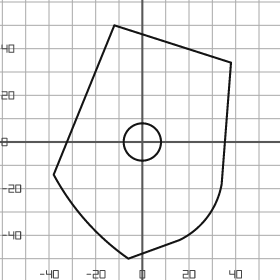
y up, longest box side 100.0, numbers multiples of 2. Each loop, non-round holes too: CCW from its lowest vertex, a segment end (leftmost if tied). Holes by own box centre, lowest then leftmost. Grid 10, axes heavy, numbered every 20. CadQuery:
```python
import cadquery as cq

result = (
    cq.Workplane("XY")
    .moveTo(-6.0, -50.0)
    .lineTo(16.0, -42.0)
    .threePointArc((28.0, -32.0), (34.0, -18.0))
    .lineTo(38.0, 34.0)
    .lineTo(-12.0, 50.0)
    .lineTo(-38.0, -14.0)
    .threePointArc((-24.0, -34.0), (-6.0, -50.0))
    .close()
    .moveTo(0.0, 0.0)
    .circle(8.0)
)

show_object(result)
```